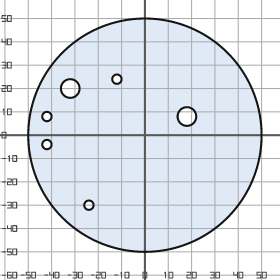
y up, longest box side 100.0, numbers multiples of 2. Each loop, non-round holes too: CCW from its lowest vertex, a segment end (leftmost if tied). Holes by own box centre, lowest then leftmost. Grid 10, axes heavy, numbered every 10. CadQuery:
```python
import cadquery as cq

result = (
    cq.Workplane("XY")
    .moveTo(0.0, 0.0)
    .circle(50.0)
    .moveTo(-24.0, -30.0)
    .circle(2.0)
    .moveTo(-42.0, -4.0)
    .circle(2.0)
    .moveTo(-42.0, 8.0)
    .circle(2.0)
    .moveTo(18.0, 8.0)
    .circle(4.0)
    .moveTo(-32.0, 20.0)
    .circle(4.0)
    .moveTo(-12.0, 24.0)
    .circle(2.0)
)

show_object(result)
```